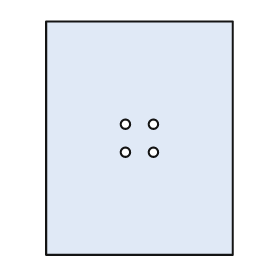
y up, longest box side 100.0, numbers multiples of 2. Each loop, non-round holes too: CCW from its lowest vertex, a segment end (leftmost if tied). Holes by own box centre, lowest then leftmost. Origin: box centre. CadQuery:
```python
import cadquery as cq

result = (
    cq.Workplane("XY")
    .moveTo(-40.0, -50.0)
    .lineTo(40.0, -50.0)
    .lineTo(40.0, 50.0)
    .lineTo(-40.0, 50.0)
    .close()
    .moveTo(-6.0, -6.0)
    .circle(2.0)
    .moveTo(6.0, -6.0)
    .circle(2.0)
    .moveTo(-6.0, 6.0)
    .circle(2.0)
    .moveTo(6.0, 6.0)
    .circle(2.0)
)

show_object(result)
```